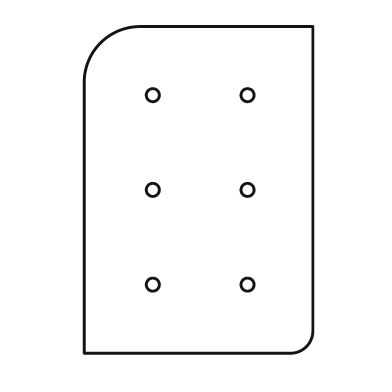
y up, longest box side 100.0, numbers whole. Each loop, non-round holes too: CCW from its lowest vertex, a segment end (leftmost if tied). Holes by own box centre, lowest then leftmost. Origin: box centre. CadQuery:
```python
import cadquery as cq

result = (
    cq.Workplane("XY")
    .moveTo(-35.0, -50.0)
    .lineTo(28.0, -50.0)
    .threePointArc((33.0, -48.0), (35.0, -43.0))
    .lineTo(35.0, 50.0)
    .lineTo(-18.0, 50.0)
    .threePointArc((-30.0, 45.0), (-35.0, 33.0))
    .close()
    .moveTo(-14.0, -29.0)
    .circle(2.0)
    .moveTo(15.0, -29.0)
    .circle(2.0)
    .moveTo(-14.0, 0.0)
    .circle(2.0)
    .moveTo(15.0, 0.0)
    .circle(2.0)
    .moveTo(-14.0, 29.0)
    .circle(2.0)
    .moveTo(15.0, 29.0)
    .circle(2.0)
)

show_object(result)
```